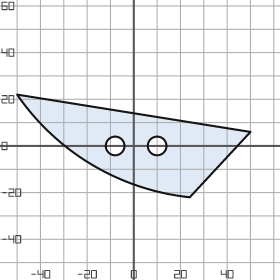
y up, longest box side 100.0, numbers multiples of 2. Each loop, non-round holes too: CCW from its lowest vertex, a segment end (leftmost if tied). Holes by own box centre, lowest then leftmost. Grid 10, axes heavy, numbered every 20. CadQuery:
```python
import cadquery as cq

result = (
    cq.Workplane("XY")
    .moveTo(24.0, -22.0)
    .lineTo(50.0, 6.0)
    .lineTo(-50.0, 22.0)
    .threePointArc((-18.0, -8.0), (24.0, -22.0))
    .close()
    .moveTo(-8.0, 0.0)
    .circle(4.0)
    .moveTo(10.0, 0.0)
    .circle(4.0)
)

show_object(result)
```